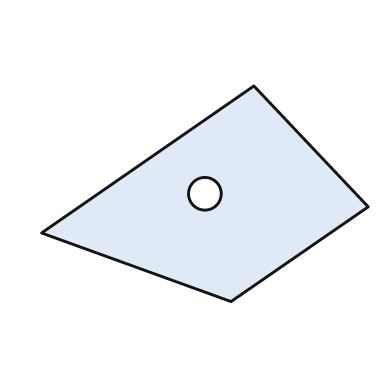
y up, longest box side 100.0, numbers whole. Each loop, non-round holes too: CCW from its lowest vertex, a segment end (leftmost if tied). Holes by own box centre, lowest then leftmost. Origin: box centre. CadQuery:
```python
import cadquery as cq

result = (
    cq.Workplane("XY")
    .moveTo(8.0, -33.0)
    .lineTo(50.0, -4.0)
    .lineTo(15.0, 33.0)
    .lineTo(-50.0, -12.0)
    .close()
    .moveTo(0.0, 0.0)
    .circle(5.0)
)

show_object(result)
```